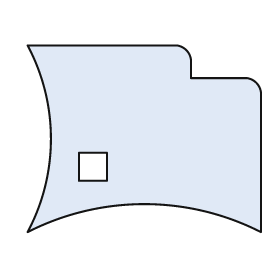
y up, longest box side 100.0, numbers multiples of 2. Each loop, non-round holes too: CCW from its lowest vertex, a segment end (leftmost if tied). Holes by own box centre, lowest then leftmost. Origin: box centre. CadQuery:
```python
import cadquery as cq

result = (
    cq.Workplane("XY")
    .moveTo(-50.0, -40.0)
    .threePointArc((0.0, -28.0), (50.0, -40.0))
    .lineTo(50.0, 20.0)
    .threePointArc((48.0, 24.0), (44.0, 26.0))
    .lineTo(20.0, 26.0)
    .lineTo(20.0, 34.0)
    .threePointArc((18.0, 38.0), (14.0, 40.0))
    .lineTo(-50.0, 40.0)
    .threePointArc((-40.0, 0.0), (-50.0, -40.0))
    .close()
    .moveTo(-28.0, -18.0)
    .lineTo(-16.0, -18.0)
    .lineTo(-16.0, -6.0)
    .lineTo(-28.0, -6.0)
    .close()
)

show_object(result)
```